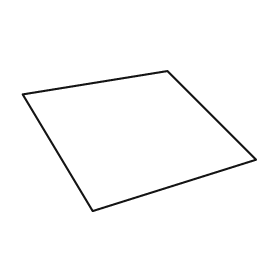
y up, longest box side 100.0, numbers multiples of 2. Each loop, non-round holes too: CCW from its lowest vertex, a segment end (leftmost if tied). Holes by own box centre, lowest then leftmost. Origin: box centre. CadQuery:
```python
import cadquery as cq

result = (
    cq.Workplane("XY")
    .moveTo(-20.0, -30.0)
    .lineTo(50.0, -8.0)
    .lineTo(12.0, 30.0)
    .lineTo(-50.0, 20.0)
    .close()
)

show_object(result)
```